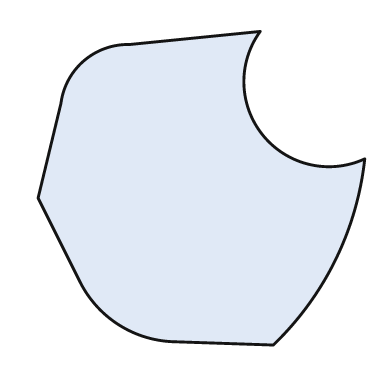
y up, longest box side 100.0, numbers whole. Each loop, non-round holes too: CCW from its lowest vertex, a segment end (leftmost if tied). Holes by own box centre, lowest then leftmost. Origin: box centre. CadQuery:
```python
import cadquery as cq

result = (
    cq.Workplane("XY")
    .moveTo(22.0, -48.0)
    .threePointArc((41.0, -22.0), (50.0, 9.0))
    .threePointArc((19.0, 16.0), (18.0, 48.0))
    .lineTo(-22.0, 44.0)
    .threePointArc((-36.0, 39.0), (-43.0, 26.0))
    .lineTo(-50.0, -3.0)
    .lineTo(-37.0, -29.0)
    .threePointArc((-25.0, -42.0), (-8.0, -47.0))
    .close()
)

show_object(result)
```